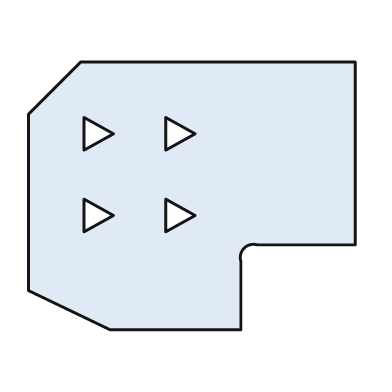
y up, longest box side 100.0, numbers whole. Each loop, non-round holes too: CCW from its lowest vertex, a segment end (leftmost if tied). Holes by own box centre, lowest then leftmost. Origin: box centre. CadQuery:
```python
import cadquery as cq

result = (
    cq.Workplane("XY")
    .moveTo(-25.0, -41.0)
    .lineTo(15.0, -41.0)
    .lineTo(15.0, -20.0)
    .threePointArc((16.0, -16.0), (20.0, -15.0))
    .lineTo(50.0, -15.0)
    .lineTo(50.0, 41.0)
    .lineTo(-34.0, 41.0)
    .lineTo(-50.0, 25.0)
    .lineTo(-50.0, -29.0)
    .close()
    .moveTo(-33.0, -11.0)
    .lineTo(-24.0, -6.0)
    .lineTo(-33.0, -1.0)
    .close()
    .moveTo(-8.0, -11.0)
    .lineTo(1.0, -6.0)
    .lineTo(-8.0, -1.0)
    .close()
    .moveTo(-33.0, 14.0)
    .lineTo(-24.0, 19.0)
    .lineTo(-33.0, 24.0)
    .close()
    .moveTo(-8.0, 14.0)
    .lineTo(1.0, 19.0)
    .lineTo(-8.0, 24.0)
    .close()
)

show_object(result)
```